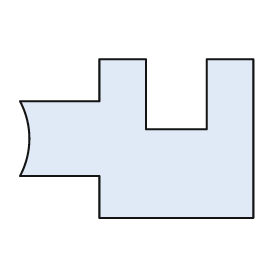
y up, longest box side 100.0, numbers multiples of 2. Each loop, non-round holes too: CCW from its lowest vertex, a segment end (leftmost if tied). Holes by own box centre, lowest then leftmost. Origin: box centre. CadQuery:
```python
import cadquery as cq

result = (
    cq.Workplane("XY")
    .moveTo(-16.0, -34.0)
    .lineTo(50.0, -34.0)
    .lineTo(50.0, 34.0)
    .lineTo(30.0, 34.0)
    .lineTo(30.0, 4.0)
    .lineTo(4.0, 4.0)
    .lineTo(4.0, 34.0)
    .lineTo(-16.0, 34.0)
    .lineTo(-16.0, 16.0)
    .lineTo(-50.0, 16.0)
    .threePointArc((-46.0, 0.0), (-50.0, -16.0))
    .lineTo(-16.0, -16.0)
    .close()
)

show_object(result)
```